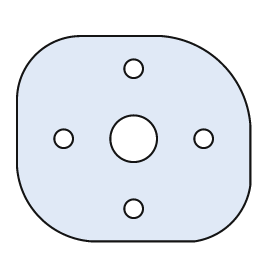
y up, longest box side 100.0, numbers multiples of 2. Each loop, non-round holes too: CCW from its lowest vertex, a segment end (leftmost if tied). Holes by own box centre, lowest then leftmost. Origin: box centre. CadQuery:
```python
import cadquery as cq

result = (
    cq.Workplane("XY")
    .moveTo(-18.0, -44.0)
    .lineTo(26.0, -44.0)
    .threePointArc((42.0, -36.0), (50.0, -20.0))
    .lineTo(50.0, 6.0)
    .threePointArc((38.0, 32.0), (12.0, 44.0))
    .lineTo(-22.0, 44.0)
    .threePointArc((-42.0, 36.0), (-50.0, 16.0))
    .lineTo(-50.0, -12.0)
    .threePointArc((-40.0, -34.0), (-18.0, -44.0))
    .close()
    .moveTo(0.0, -30.0)
    .circle(4.0)
    .moveTo(-30.0, 0.0)
    .circle(4.0)
    .moveTo(0.0, 0.0)
    .circle(10.0)
    .moveTo(30.0, 0.0)
    .circle(4.0)
    .moveTo(0.0, 30.0)
    .circle(4.0)
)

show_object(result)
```